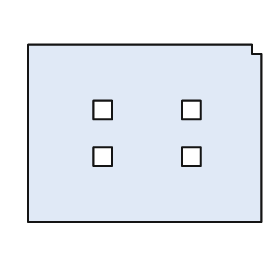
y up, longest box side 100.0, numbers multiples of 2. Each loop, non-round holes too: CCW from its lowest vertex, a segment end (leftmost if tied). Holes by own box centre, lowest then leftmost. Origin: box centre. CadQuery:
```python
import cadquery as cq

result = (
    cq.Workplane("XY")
    .moveTo(-50.0, -38.0)
    .lineTo(50.0, -38.0)
    .lineTo(50.0, 34.0)
    .lineTo(46.0, 34.0)
    .lineTo(46.0, 38.0)
    .lineTo(-50.0, 38.0)
    .close()
    .moveTo(-22.0, -14.0)
    .lineTo(-14.0, -14.0)
    .lineTo(-14.0, -6.0)
    .lineTo(-22.0, -6.0)
    .close()
    .moveTo(16.0, -14.0)
    .lineTo(24.0, -14.0)
    .lineTo(24.0, -6.0)
    .lineTo(16.0, -6.0)
    .close()
    .moveTo(-22.0, 6.0)
    .lineTo(-14.0, 6.0)
    .lineTo(-14.0, 14.0)
    .lineTo(-22.0, 14.0)
    .close()
    .moveTo(16.0, 6.0)
    .lineTo(24.0, 6.0)
    .lineTo(24.0, 14.0)
    .lineTo(16.0, 14.0)
    .close()
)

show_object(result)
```